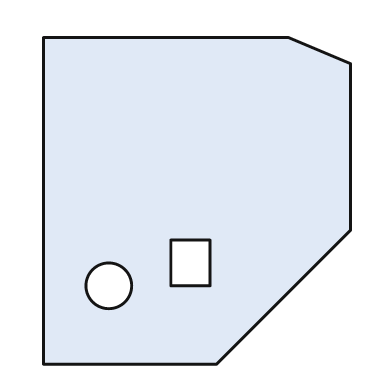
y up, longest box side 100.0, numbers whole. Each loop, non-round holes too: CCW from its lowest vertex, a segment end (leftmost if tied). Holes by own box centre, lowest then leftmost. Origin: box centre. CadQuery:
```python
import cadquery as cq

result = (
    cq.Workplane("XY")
    .moveTo(-47.0, -50.0)
    .lineTo(6.0, -50.0)
    .lineTo(47.0, -9.0)
    .lineTo(47.0, 42.0)
    .lineTo(28.0, 50.0)
    .lineTo(-47.0, 50.0)
    .close()
    .moveTo(-27.0, -26.0)
    .circle(7.0)
    .moveTo(-8.0, -26.0)
    .lineTo(4.0, -26.0)
    .lineTo(4.0, -12.0)
    .lineTo(-8.0, -12.0)
    .close()
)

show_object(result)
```